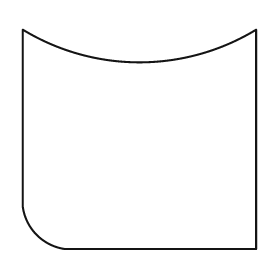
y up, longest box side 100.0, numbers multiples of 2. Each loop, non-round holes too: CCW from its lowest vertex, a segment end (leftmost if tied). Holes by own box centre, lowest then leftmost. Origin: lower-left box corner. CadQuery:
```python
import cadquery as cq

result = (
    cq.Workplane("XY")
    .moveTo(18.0, 0.0)
    .lineTo(100.0, 0.0)
    .lineTo(100.0, 94.0)
    .threePointArc((50.0, 80.0), (0.0, 94.0))
    .lineTo(0.0, 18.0)
    .threePointArc((6.0, 6.0), (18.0, 0.0))
    .close()
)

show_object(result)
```